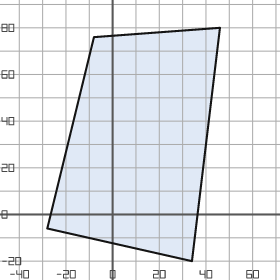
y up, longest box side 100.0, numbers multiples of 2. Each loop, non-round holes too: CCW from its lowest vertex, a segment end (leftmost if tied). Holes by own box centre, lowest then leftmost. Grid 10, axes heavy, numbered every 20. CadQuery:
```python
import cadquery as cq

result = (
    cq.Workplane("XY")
    .moveTo(34.0, -20.0)
    .lineTo(46.0, 80.0)
    .lineTo(-8.0, 76.0)
    .lineTo(-28.0, -6.0)
    .close()
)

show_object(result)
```